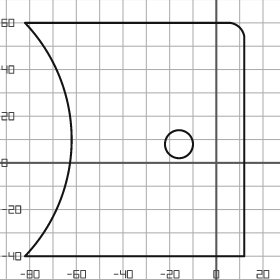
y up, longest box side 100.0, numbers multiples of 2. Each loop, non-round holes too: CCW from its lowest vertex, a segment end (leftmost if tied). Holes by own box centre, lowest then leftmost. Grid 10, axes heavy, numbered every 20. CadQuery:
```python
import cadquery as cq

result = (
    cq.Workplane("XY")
    .moveTo(-82.0, -40.0)
    .lineTo(12.0, -40.0)
    .lineTo(12.0, 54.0)
    .threePointArc((10.0, 58.0), (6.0, 60.0))
    .lineTo(-82.0, 60.0)
    .threePointArc((-62.0, 10.0), (-82.0, -40.0))
    .close()
    .moveTo(-16.0, 8.0)
    .circle(6.0)
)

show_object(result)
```